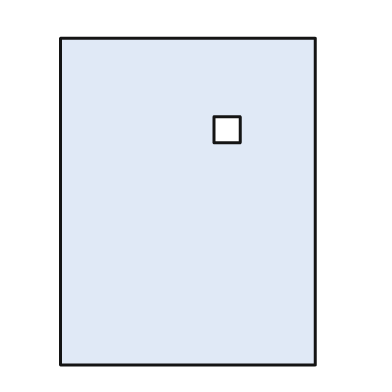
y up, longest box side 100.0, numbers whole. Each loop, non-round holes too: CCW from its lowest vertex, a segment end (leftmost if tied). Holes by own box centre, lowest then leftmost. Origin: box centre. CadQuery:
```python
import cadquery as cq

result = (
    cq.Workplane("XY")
    .moveTo(-39.0, -50.0)
    .lineTo(39.0, -50.0)
    .lineTo(39.0, 50.0)
    .lineTo(-39.0, 50.0)
    .close()
    .moveTo(8.0, 18.0)
    .lineTo(16.0, 18.0)
    .lineTo(16.0, 26.0)
    .lineTo(8.0, 26.0)
    .close()
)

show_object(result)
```